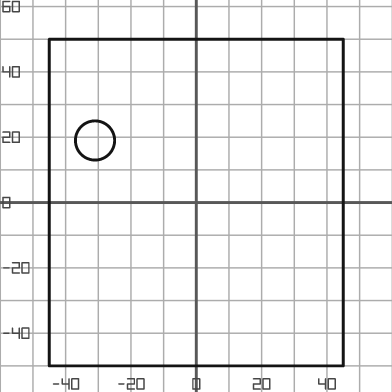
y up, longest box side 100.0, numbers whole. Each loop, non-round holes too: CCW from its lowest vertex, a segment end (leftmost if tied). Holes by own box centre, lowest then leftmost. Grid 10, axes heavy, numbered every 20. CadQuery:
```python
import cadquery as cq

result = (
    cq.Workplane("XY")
    .moveTo(-45.0, -50.0)
    .lineTo(45.0, -50.0)
    .lineTo(45.0, 50.0)
    .lineTo(-45.0, 50.0)
    .close()
    .moveTo(-31.0, 19.0)
    .circle(6.0)
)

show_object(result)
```